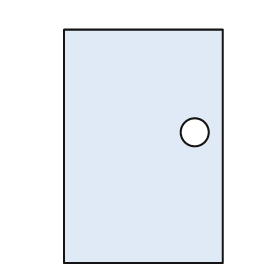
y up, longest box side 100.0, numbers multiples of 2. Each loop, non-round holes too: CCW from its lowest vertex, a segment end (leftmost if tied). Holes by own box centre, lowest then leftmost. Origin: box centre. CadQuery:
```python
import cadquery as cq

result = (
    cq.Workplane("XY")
    .moveTo(-34.0, -50.0)
    .lineTo(34.0, -50.0)
    .lineTo(34.0, 50.0)
    .lineTo(-34.0, 50.0)
    .close()
    .moveTo(22.0, 6.0)
    .circle(6.0)
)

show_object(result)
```